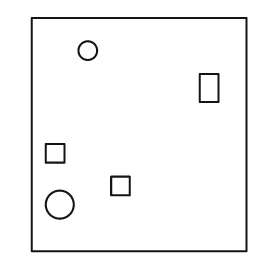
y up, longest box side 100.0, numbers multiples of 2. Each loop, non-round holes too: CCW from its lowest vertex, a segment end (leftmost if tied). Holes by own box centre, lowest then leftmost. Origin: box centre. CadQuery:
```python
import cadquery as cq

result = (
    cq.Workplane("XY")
    .moveTo(-46.0, -50.0)
    .lineTo(46.0, -50.0)
    .lineTo(46.0, 50.0)
    .lineTo(-46.0, 50.0)
    .close()
    .moveTo(-34.0, -30.0)
    .circle(6.0)
    .moveTo(-12.0, -26.0)
    .lineTo(-4.0, -26.0)
    .lineTo(-4.0, -18.0)
    .lineTo(-12.0, -18.0)
    .close()
    .moveTo(-40.0, -12.0)
    .lineTo(-32.0, -12.0)
    .lineTo(-32.0, -4.0)
    .lineTo(-40.0, -4.0)
    .close()
    .moveTo(26.0, 14.0)
    .lineTo(34.0, 14.0)
    .lineTo(34.0, 26.0)
    .lineTo(26.0, 26.0)
    .close()
    .moveTo(-22.0, 36.0)
    .circle(4.0)
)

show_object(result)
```